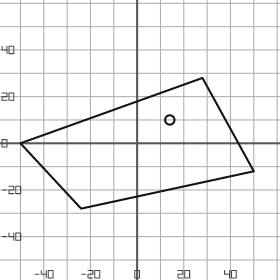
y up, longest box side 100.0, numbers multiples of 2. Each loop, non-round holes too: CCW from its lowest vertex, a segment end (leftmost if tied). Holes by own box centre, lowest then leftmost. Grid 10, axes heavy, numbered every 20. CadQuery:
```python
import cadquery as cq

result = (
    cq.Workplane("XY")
    .moveTo(-24.0, -28.0)
    .lineTo(50.0, -12.0)
    .lineTo(28.0, 28.0)
    .lineTo(-50.0, 0.0)
    .close()
    .moveTo(14.0, 10.0)
    .circle(2.0)
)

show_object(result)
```